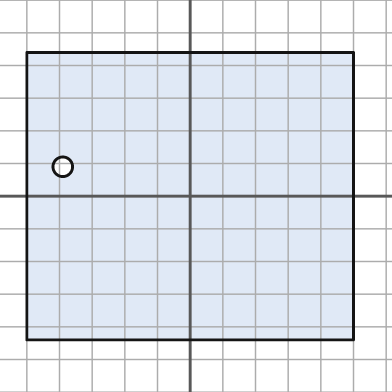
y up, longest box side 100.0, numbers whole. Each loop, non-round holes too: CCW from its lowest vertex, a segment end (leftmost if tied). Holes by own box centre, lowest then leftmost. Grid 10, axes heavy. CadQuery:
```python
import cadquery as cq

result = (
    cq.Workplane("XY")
    .moveTo(-50.0, -44.0)
    .lineTo(50.0, -44.0)
    .lineTo(50.0, 44.0)
    .lineTo(-50.0, 44.0)
    .close()
    .moveTo(-39.0, 9.0)
    .circle(3.0)
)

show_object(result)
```